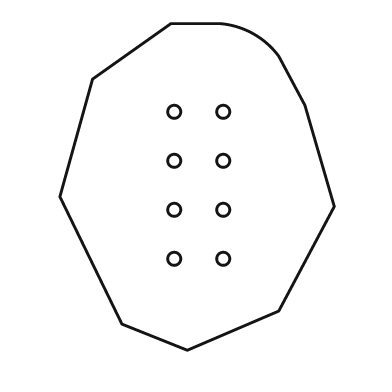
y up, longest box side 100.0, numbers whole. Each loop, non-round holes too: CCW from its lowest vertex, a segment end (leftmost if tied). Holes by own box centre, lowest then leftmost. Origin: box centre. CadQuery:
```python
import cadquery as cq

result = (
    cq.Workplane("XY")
    .moveTo(-3.0, -50.0)
    .lineTo(25.0, -38.0)
    .lineTo(42.0, -6.0)
    .lineTo(33.0, 25.0)
    .lineTo(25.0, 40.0)
    .threePointArc((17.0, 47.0), (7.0, 50.0))
    .lineTo(-8.0, 50.0)
    .lineTo(-32.0, 33.0)
    .lineTo(-42.0, -3.0)
    .lineTo(-23.0, -42.0)
    .close()
    .moveTo(-7.0, -22.0)
    .circle(2.0)
    .moveTo(8.0, -22.0)
    .circle(2.0)
    .moveTo(-7.0, -7.0)
    .circle(2.0)
    .moveTo(8.0, -7.0)
    .circle(2.0)
    .moveTo(-7.0, 8.0)
    .circle(2.0)
    .moveTo(8.0, 8.0)
    .circle(2.0)
    .moveTo(-7.0, 23.0)
    .circle(2.0)
    .moveTo(8.0, 23.0)
    .circle(2.0)
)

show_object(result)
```